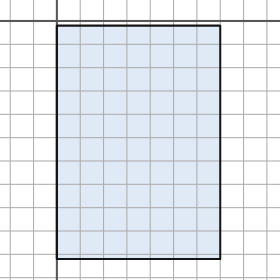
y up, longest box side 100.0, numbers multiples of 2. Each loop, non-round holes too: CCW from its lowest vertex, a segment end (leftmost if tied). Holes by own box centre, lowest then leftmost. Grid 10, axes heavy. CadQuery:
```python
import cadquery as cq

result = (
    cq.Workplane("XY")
    .moveTo(0.0, -102.0)
    .lineTo(70.0, -102.0)
    .lineTo(70.0, -2.0)
    .lineTo(0.0, -2.0)
    .close()
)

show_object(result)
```